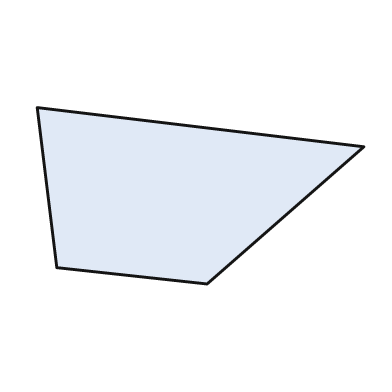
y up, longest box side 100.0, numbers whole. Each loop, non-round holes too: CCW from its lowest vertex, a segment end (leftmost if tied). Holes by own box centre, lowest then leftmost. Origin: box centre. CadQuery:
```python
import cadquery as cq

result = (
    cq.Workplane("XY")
    .moveTo(2.0, -27.0)
    .lineTo(50.0, 15.0)
    .lineTo(-50.0, 27.0)
    .lineTo(-44.0, -22.0)
    .close()
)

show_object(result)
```